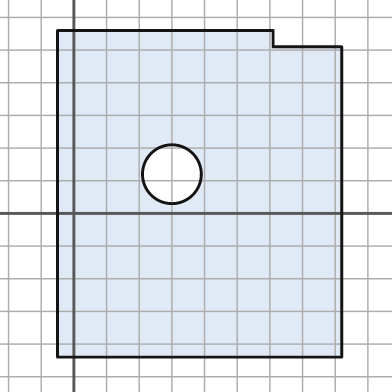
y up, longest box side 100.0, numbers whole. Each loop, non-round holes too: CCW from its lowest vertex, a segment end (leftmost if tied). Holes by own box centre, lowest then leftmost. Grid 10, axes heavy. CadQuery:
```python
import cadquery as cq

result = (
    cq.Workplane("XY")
    .moveTo(-5.0, -44.0)
    .lineTo(82.0, -44.0)
    .lineTo(82.0, 51.0)
    .lineTo(61.0, 51.0)
    .lineTo(61.0, 56.0)
    .lineTo(-5.0, 56.0)
    .close()
    .moveTo(30.0, 12.0)
    .circle(9.0)
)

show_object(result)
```